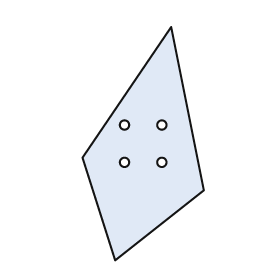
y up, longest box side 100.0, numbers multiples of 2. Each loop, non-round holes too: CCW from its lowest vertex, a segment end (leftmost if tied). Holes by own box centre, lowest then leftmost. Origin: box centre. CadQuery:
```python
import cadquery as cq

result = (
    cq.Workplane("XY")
    .moveTo(-12.0, -50.0)
    .lineTo(26.0, -20.0)
    .lineTo(12.0, 50.0)
    .lineTo(-26.0, -6.0)
    .close()
    .moveTo(-8.0, -8.0)
    .circle(2.0)
    .moveTo(8.0, -8.0)
    .circle(2.0)
    .moveTo(-8.0, 8.0)
    .circle(2.0)
    .moveTo(8.0, 8.0)
    .circle(2.0)
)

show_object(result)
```